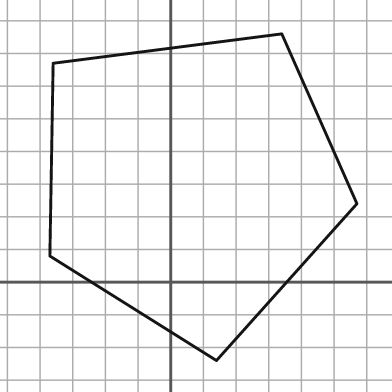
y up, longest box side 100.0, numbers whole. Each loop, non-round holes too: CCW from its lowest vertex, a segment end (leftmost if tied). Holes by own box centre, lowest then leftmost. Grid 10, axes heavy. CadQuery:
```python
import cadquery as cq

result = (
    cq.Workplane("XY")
    .moveTo(14.0, -24.0)
    .lineTo(57.0, 24.0)
    .lineTo(34.0, 76.0)
    .lineTo(-36.0, 67.0)
    .lineTo(-37.0, 8.0)
    .close()
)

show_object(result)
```